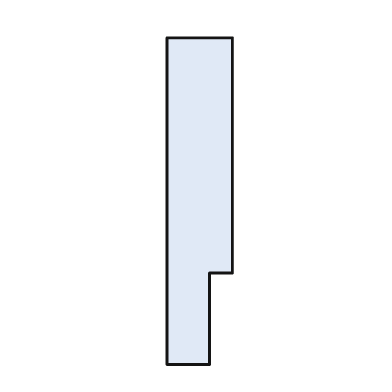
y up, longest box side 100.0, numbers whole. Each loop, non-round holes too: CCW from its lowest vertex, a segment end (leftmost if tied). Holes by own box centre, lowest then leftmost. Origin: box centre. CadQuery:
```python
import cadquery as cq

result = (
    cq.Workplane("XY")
    .moveTo(-10.0, -50.0)
    .lineTo(3.0, -50.0)
    .lineTo(3.0, -22.0)
    .lineTo(10.0, -22.0)
    .lineTo(10.0, 50.0)
    .lineTo(-10.0, 50.0)
    .close()
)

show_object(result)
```